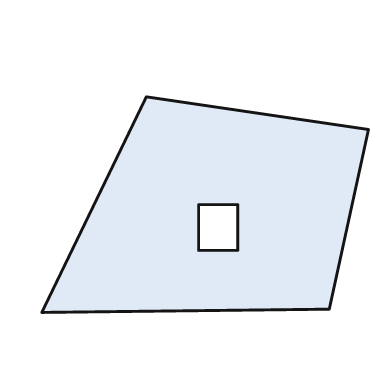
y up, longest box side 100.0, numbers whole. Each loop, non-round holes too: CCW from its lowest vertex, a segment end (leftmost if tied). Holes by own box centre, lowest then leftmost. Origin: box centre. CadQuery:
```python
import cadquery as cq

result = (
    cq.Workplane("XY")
    .moveTo(-50.0, -33.0)
    .lineTo(38.0, -32.0)
    .lineTo(50.0, 23.0)
    .lineTo(-18.0, 33.0)
    .close()
    .moveTo(-2.0, -14.0)
    .lineTo(10.0, -14.0)
    .lineTo(10.0, 0.0)
    .lineTo(-2.0, 0.0)
    .close()
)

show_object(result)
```